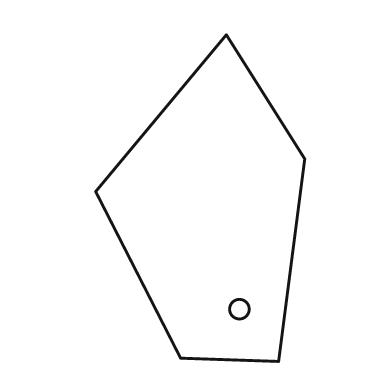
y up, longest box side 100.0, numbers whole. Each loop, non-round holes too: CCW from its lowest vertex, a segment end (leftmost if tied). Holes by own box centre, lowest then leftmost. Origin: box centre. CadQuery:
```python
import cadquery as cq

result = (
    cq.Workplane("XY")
    .moveTo(24.0, -50.0)
    .lineTo(32.0, 12.0)
    .lineTo(8.0, 50.0)
    .lineTo(-32.0, 2.0)
    .lineTo(-6.0, -49.0)
    .close()
    .moveTo(12.0, -34.0)
    .circle(3.0)
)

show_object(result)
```